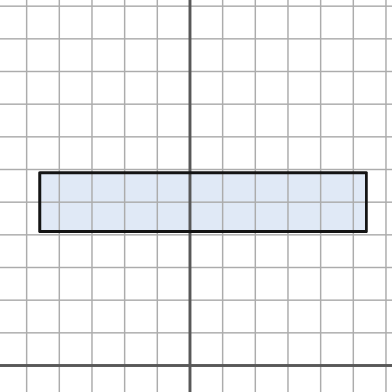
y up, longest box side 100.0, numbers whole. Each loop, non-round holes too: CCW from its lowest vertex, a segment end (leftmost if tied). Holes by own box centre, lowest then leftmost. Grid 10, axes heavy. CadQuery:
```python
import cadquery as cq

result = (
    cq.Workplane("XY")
    .moveTo(-46.0, 41.0)
    .lineTo(54.0, 41.0)
    .lineTo(54.0, 59.0)
    .lineTo(-46.0, 59.0)
    .close()
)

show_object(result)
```